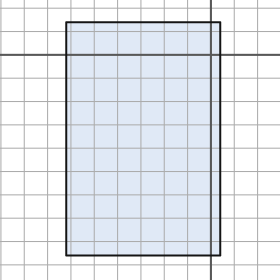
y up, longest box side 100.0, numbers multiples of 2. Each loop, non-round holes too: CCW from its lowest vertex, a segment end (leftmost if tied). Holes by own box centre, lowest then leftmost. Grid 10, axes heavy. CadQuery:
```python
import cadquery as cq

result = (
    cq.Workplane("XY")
    .moveTo(-62.0, -86.0)
    .lineTo(4.0, -86.0)
    .lineTo(4.0, 14.0)
    .lineTo(-62.0, 14.0)
    .close()
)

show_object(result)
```